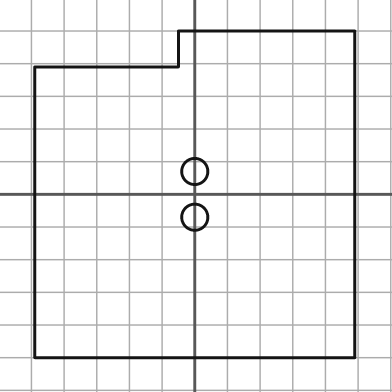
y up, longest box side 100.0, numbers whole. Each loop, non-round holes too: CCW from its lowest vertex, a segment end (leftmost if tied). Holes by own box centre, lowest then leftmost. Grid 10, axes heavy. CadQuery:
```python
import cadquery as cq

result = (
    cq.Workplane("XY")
    .moveTo(-49.0, -50.0)
    .lineTo(49.0, -50.0)
    .lineTo(49.0, 50.0)
    .lineTo(-5.0, 50.0)
    .lineTo(-5.0, 39.0)
    .lineTo(-49.0, 39.0)
    .close()
    .moveTo(0.0, -7.0)
    .circle(4.0)
    .moveTo(0.0, 7.0)
    .circle(4.0)
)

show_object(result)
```